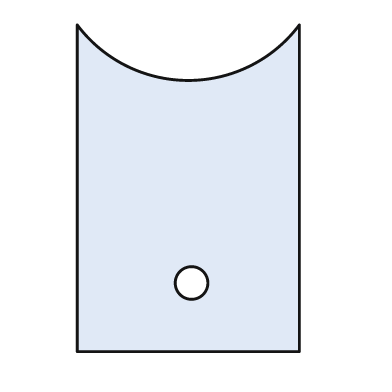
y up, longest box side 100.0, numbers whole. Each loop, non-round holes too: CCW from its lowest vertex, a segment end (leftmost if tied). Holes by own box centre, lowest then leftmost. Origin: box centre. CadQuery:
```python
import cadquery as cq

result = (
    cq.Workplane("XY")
    .moveTo(-34.0, -50.0)
    .lineTo(34.0, -50.0)
    .lineTo(34.0, 50.0)
    .threePointArc((0.0, 33.0), (-34.0, 50.0))
    .close()
    .moveTo(1.0, -29.0)
    .circle(5.0)
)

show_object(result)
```